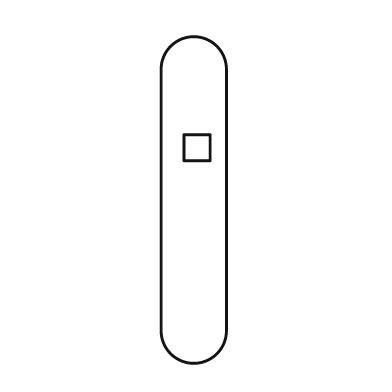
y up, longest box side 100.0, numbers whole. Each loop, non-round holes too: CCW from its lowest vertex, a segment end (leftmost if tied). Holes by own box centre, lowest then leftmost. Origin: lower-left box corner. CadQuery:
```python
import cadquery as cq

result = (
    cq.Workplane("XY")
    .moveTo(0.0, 10.0)
    .threePointArc((10.0, 0.0), (20.0, 10.0))
    .lineTo(20.0, 90.0)
    .threePointArc((10.0, 100.0), (0.0, 90.0))
    .close()
    .moveTo(7.0, 62.0)
    .lineTo(15.0, 62.0)
    .lineTo(15.0, 70.0)
    .lineTo(7.0, 70.0)
    .close()
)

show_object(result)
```